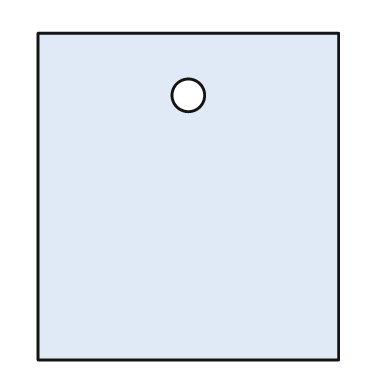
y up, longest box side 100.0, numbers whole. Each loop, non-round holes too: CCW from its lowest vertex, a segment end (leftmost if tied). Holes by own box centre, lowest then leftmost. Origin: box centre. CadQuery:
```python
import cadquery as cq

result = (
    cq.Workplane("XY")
    .moveTo(-46.0, -50.0)
    .lineTo(46.0, -50.0)
    .lineTo(46.0, 50.0)
    .lineTo(-46.0, 50.0)
    .close()
    .moveTo(0.0, 31.0)
    .circle(5.0)
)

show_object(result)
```